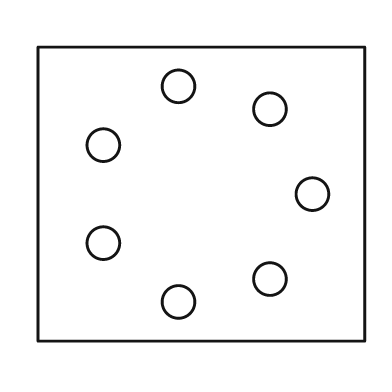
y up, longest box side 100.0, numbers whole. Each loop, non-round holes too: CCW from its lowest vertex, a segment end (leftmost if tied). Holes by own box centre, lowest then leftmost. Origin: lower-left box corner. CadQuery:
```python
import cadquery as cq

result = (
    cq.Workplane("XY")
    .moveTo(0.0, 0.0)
    .lineTo(100.0, 0.0)
    .lineTo(100.0, 90.0)
    .lineTo(0.0, 90.0)
    .close()
    .moveTo(43.0, 12.0)
    .circle(5.0)
    .moveTo(71.0, 19.0)
    .circle(5.0)
    .moveTo(20.0, 30.0)
    .circle(5.0)
    .moveTo(84.0, 45.0)
    .circle(5.0)
    .moveTo(20.0, 60.0)
    .circle(5.0)
    .moveTo(71.0, 71.0)
    .circle(5.0)
    .moveTo(43.0, 78.0)
    .circle(5.0)
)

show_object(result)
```